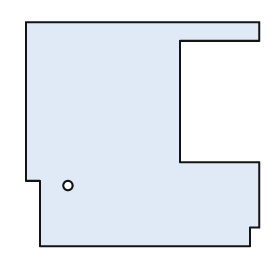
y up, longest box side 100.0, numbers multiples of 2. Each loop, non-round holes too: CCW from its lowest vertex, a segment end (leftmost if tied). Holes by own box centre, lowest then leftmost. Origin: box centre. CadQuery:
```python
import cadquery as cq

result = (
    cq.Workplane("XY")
    .moveTo(-44.0, -48.0)
    .lineTo(46.0, -48.0)
    .lineTo(46.0, -40.0)
    .lineTo(50.0, -40.0)
    .lineTo(50.0, -12.0)
    .lineTo(16.0, -12.0)
    .lineTo(16.0, 40.0)
    .lineTo(50.0, 40.0)
    .lineTo(50.0, 48.0)
    .lineTo(-50.0, 48.0)
    .lineTo(-50.0, -20.0)
    .lineTo(-44.0, -20.0)
    .close()
    .moveTo(-32.0, -22.0)
    .circle(2.0)
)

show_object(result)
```